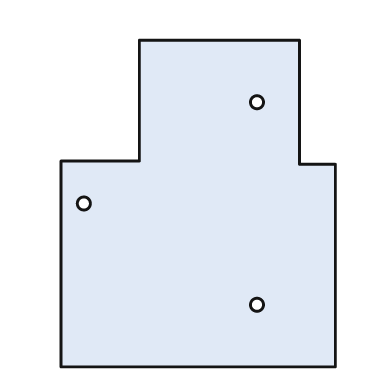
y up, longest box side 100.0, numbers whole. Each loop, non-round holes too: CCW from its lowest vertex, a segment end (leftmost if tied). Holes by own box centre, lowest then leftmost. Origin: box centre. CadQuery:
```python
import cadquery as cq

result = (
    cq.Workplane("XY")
    .moveTo(-42.0, -50.0)
    .lineTo(42.0, -50.0)
    .lineTo(42.0, 12.0)
    .lineTo(31.0, 12.0)
    .lineTo(31.0, 50.0)
    .lineTo(-18.0, 50.0)
    .lineTo(-18.0, 13.0)
    .lineTo(-42.0, 13.0)
    .close()
    .moveTo(18.0, -31.0)
    .circle(2.0)
    .moveTo(-35.0, 0.0)
    .circle(2.0)
    .moveTo(18.0, 31.0)
    .circle(2.0)
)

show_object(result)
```